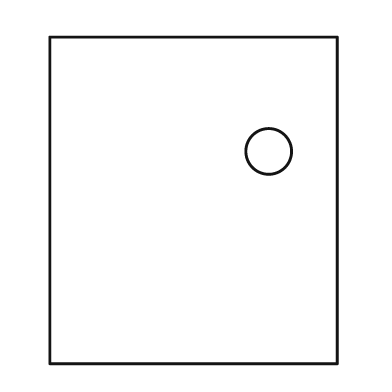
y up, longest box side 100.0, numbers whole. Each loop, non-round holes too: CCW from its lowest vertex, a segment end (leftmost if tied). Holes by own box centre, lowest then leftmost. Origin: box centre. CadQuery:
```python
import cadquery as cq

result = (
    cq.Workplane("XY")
    .moveTo(-44.0, -50.0)
    .lineTo(44.0, -50.0)
    .lineTo(44.0, 50.0)
    .lineTo(-44.0, 50.0)
    .close()
    .moveTo(23.0, 15.0)
    .circle(7.0)
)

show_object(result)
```